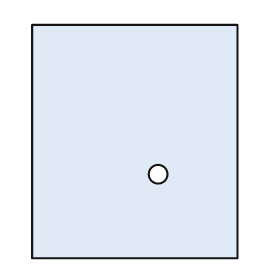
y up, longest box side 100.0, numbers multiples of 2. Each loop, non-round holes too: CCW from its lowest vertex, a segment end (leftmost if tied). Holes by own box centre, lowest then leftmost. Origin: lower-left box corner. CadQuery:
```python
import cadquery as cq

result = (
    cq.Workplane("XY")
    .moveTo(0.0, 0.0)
    .lineTo(88.0, 0.0)
    .lineTo(88.0, 100.0)
    .lineTo(0.0, 100.0)
    .close()
    .moveTo(54.0, 36.0)
    .circle(4.0)
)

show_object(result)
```